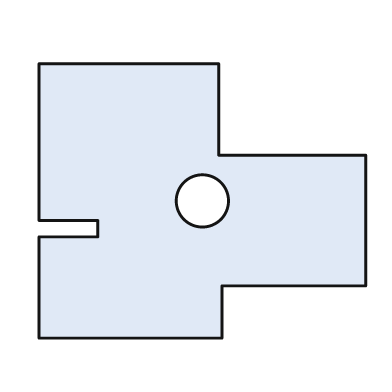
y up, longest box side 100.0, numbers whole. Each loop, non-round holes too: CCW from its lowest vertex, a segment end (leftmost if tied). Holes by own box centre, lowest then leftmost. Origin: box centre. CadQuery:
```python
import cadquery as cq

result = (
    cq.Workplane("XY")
    .moveTo(-50.0, -42.0)
    .lineTo(6.0, -42.0)
    .lineTo(6.0, -26.0)
    .lineTo(50.0, -26.0)
    .lineTo(50.0, 14.0)
    .lineTo(5.0, 14.0)
    .lineTo(5.0, 42.0)
    .lineTo(-50.0, 42.0)
    .lineTo(-50.0, -6.0)
    .lineTo(-32.0, -6.0)
    .lineTo(-32.0, -11.0)
    .lineTo(-50.0, -11.0)
    .close()
    .moveTo(0.0, 0.0)
    .circle(8.0)
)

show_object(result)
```